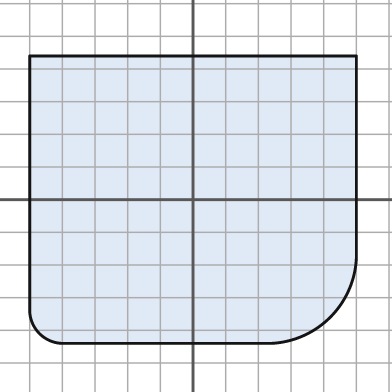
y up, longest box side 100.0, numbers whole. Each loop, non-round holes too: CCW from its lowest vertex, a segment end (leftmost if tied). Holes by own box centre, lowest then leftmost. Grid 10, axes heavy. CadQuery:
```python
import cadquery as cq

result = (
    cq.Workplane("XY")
    .moveTo(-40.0, -44.0)
    .lineTo(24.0, -44.0)
    .threePointArc((42.0, -36.0), (50.0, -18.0))
    .lineTo(50.0, 44.0)
    .lineTo(-50.0, 44.0)
    .lineTo(-50.0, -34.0)
    .threePointArc((-47.0, -41.0), (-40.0, -44.0))
    .close()
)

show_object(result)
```